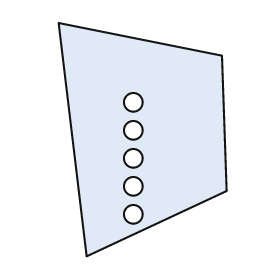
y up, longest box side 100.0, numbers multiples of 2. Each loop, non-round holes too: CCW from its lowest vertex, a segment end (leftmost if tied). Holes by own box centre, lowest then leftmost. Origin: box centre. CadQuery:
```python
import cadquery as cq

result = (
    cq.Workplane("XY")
    .moveTo(-24.0, -50.0)
    .lineTo(36.0, -22.0)
    .lineTo(34.0, 36.0)
    .lineTo(-36.0, 50.0)
    .close()
    .moveTo(-4.0, -32.0)
    .circle(4.0)
    .moveTo(-4.0, -20.0)
    .circle(4.0)
    .moveTo(-4.0, -8.0)
    .circle(4.0)
    .moveTo(-4.0, 4.0)
    .circle(4.0)
    .moveTo(-4.0, 16.0)
    .circle(4.0)
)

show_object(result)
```